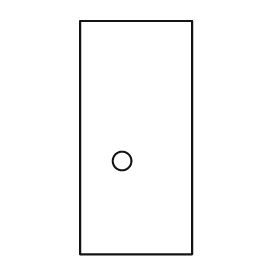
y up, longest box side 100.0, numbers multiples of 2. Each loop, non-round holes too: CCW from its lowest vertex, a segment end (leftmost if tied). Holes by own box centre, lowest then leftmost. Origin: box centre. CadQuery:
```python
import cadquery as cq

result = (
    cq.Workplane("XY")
    .moveTo(-24.0, -50.0)
    .lineTo(24.0, -50.0)
    .lineTo(24.0, 50.0)
    .lineTo(-24.0, 50.0)
    .close()
    .moveTo(-6.0, -10.0)
    .circle(4.0)
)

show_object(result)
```